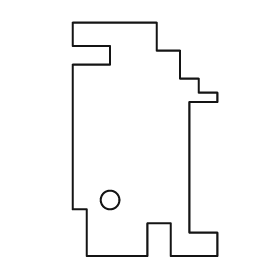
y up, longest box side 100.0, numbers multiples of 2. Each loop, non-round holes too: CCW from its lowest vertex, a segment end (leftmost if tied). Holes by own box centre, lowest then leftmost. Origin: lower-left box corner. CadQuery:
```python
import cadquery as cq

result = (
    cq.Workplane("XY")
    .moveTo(6.0, 0.0)
    .lineTo(32.0, 0.0)
    .lineTo(32.0, 14.0)
    .lineTo(42.0, 14.0)
    .lineTo(42.0, 0.0)
    .lineTo(62.0, 0.0)
    .lineTo(62.0, 10.0)
    .lineTo(50.0, 10.0)
    .lineTo(50.0, 66.0)
    .lineTo(62.0, 66.0)
    .lineTo(62.0, 70.0)
    .lineTo(54.0, 70.0)
    .lineTo(54.0, 76.0)
    .lineTo(46.0, 76.0)
    .lineTo(46.0, 88.0)
    .lineTo(36.0, 88.0)
    .lineTo(36.0, 100.0)
    .lineTo(0.0, 100.0)
    .lineTo(0.0, 90.0)
    .lineTo(16.0, 90.0)
    .lineTo(16.0, 82.0)
    .lineTo(0.0, 82.0)
    .lineTo(0.0, 20.0)
    .lineTo(6.0, 20.0)
    .close()
    .moveTo(16.0, 24.0)
    .circle(4.0)
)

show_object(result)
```